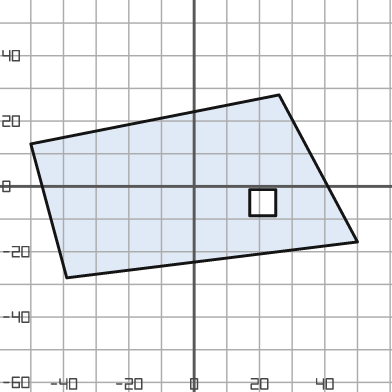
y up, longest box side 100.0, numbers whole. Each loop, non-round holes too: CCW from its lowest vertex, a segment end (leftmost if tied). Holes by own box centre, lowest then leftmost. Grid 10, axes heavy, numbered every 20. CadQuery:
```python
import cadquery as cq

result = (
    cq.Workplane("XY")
    .moveTo(-39.0, -28.0)
    .lineTo(50.0, -17.0)
    .lineTo(26.0, 28.0)
    .lineTo(-50.0, 13.0)
    .close()
    .moveTo(17.0, -9.0)
    .lineTo(25.0, -9.0)
    .lineTo(25.0, -1.0)
    .lineTo(17.0, -1.0)
    .close()
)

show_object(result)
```